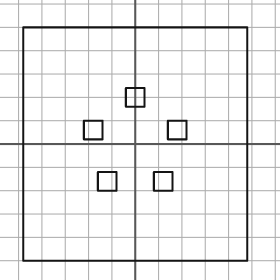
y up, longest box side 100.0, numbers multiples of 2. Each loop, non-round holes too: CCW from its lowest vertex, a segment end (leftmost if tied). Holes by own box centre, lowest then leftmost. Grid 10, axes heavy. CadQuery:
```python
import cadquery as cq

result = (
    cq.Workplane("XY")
    .moveTo(-48.0, -50.0)
    .lineTo(48.0, -50.0)
    .lineTo(48.0, 50.0)
    .lineTo(-48.0, 50.0)
    .close()
    .moveTo(-16.0, -20.0)
    .lineTo(-8.0, -20.0)
    .lineTo(-8.0, -12.0)
    .lineTo(-16.0, -12.0)
    .close()
    .moveTo(8.0, -20.0)
    .lineTo(16.0, -20.0)
    .lineTo(16.0, -12.0)
    .lineTo(8.0, -12.0)
    .close()
    .moveTo(-22.0, 2.0)
    .lineTo(-14.0, 2.0)
    .lineTo(-14.0, 10.0)
    .lineTo(-22.0, 10.0)
    .close()
    .moveTo(14.0, 2.0)
    .lineTo(22.0, 2.0)
    .lineTo(22.0, 10.0)
    .lineTo(14.0, 10.0)
    .close()
    .moveTo(-4.0, 16.0)
    .lineTo(4.0, 16.0)
    .lineTo(4.0, 24.0)
    .lineTo(-4.0, 24.0)
    .close()
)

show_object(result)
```